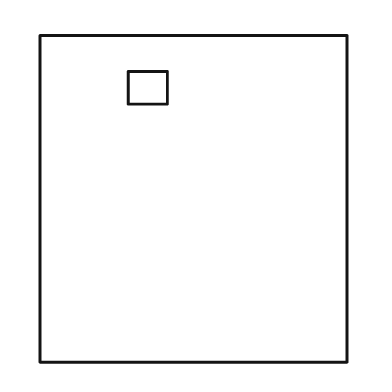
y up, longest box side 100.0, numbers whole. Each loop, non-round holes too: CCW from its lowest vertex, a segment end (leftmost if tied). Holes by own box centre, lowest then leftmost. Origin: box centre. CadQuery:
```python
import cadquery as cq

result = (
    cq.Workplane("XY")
    .moveTo(-47.0, -50.0)
    .lineTo(47.0, -50.0)
    .lineTo(47.0, 50.0)
    .lineTo(-47.0, 50.0)
    .close()
    .moveTo(-20.0, 29.0)
    .lineTo(-8.0, 29.0)
    .lineTo(-8.0, 39.0)
    .lineTo(-20.0, 39.0)
    .close()
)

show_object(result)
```